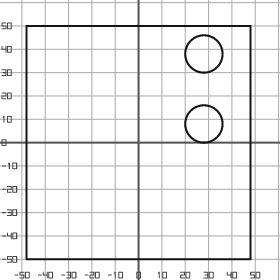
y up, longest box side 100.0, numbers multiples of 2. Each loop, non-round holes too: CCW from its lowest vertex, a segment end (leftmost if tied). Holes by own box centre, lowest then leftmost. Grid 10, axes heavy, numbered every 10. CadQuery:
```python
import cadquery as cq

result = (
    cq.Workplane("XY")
    .moveTo(-48.0, -50.0)
    .lineTo(48.0, -50.0)
    .lineTo(48.0, 50.0)
    .lineTo(-48.0, 50.0)
    .close()
    .moveTo(28.0, 8.0)
    .circle(8.0)
    .moveTo(28.0, 38.0)
    .circle(8.0)
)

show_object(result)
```